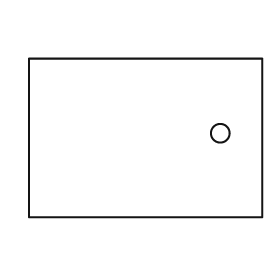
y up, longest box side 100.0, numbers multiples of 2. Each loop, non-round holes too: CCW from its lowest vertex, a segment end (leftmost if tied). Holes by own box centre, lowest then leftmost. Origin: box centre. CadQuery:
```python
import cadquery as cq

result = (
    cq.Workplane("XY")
    .moveTo(-50.0, -34.0)
    .lineTo(50.0, -34.0)
    .lineTo(50.0, 34.0)
    .lineTo(-50.0, 34.0)
    .close()
    .moveTo(32.0, 2.0)
    .circle(4.0)
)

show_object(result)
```